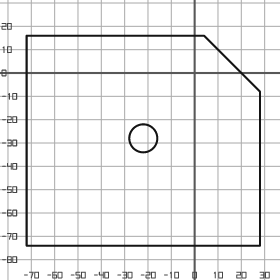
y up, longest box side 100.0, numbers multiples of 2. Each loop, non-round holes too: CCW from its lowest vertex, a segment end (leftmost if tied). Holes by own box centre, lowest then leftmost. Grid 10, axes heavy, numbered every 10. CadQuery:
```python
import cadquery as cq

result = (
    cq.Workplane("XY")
    .moveTo(-72.0, -74.0)
    .lineTo(28.0, -74.0)
    .lineTo(28.0, -8.0)
    .lineTo(4.0, 16.0)
    .lineTo(-72.0, 16.0)
    .close()
    .moveTo(-22.0, -28.0)
    .circle(6.0)
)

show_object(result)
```